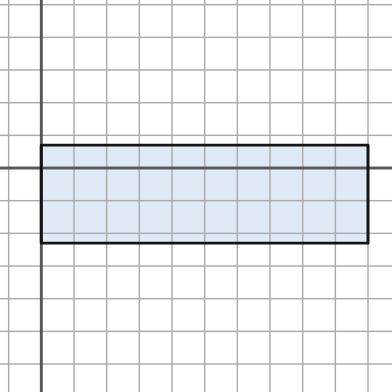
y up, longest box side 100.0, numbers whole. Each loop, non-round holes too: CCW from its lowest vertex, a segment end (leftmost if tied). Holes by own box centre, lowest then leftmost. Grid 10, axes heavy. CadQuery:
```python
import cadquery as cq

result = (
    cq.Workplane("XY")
    .moveTo(0.0, -23.0)
    .lineTo(100.0, -23.0)
    .lineTo(100.0, 7.0)
    .lineTo(0.0, 7.0)
    .close()
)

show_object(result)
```